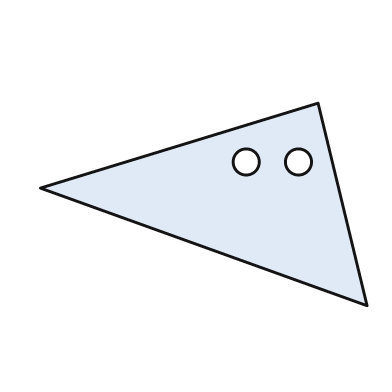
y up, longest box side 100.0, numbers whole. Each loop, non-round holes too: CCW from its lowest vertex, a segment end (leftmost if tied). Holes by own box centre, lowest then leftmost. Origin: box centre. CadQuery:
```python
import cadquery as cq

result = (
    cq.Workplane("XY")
    .moveTo(50.0, -31.0)
    .lineTo(35.0, 31.0)
    .lineTo(-50.0, 5.0)
    .close()
    .moveTo(13.0, 13.0)
    .circle(4.0)
    .moveTo(29.0, 13.0)
    .circle(4.0)
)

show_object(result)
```